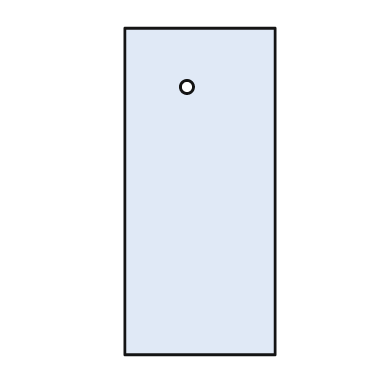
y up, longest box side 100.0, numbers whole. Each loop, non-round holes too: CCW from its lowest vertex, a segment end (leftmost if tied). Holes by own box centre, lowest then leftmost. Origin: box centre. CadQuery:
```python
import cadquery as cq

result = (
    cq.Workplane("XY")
    .moveTo(-23.0, -50.0)
    .lineTo(23.0, -50.0)
    .lineTo(23.0, 50.0)
    .lineTo(-23.0, 50.0)
    .close()
    .moveTo(-4.0, 32.0)
    .circle(2.0)
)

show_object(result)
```